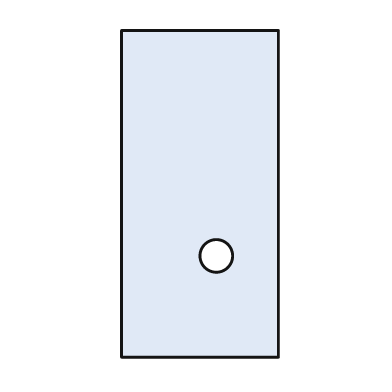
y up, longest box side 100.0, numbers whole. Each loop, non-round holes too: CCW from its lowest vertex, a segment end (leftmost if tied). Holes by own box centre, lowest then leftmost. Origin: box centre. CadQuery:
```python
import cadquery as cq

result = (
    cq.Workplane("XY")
    .moveTo(-24.0, -50.0)
    .lineTo(24.0, -50.0)
    .lineTo(24.0, 50.0)
    .lineTo(-24.0, 50.0)
    .close()
    .moveTo(5.0, -19.0)
    .circle(5.0)
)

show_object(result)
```